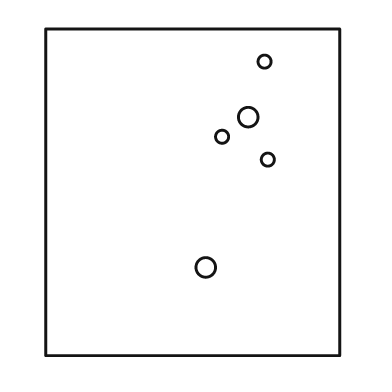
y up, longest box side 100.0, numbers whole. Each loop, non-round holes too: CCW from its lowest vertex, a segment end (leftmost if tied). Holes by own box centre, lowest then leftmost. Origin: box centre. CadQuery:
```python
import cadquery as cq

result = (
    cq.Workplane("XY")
    .moveTo(-45.0, -50.0)
    .lineTo(45.0, -50.0)
    .lineTo(45.0, 50.0)
    .lineTo(-45.0, 50.0)
    .close()
    .moveTo(4.0, -23.0)
    .circle(3.0)
    .moveTo(23.0, 10.0)
    .circle(2.0)
    .moveTo(9.0, 17.0)
    .circle(2.0)
    .moveTo(17.0, 23.0)
    .circle(3.0)
    .moveTo(22.0, 40.0)
    .circle(2.0)
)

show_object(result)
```